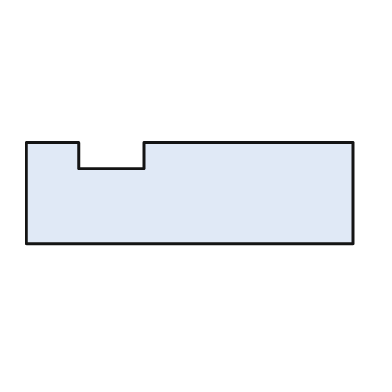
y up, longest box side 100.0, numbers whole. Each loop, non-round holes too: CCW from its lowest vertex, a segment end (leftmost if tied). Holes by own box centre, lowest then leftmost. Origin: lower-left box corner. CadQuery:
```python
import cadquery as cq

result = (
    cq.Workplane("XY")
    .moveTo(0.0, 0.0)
    .lineTo(100.0, 0.0)
    .lineTo(100.0, 31.0)
    .lineTo(36.0, 31.0)
    .lineTo(36.0, 23.0)
    .lineTo(16.0, 23.0)
    .lineTo(16.0, 31.0)
    .lineTo(0.0, 31.0)
    .close()
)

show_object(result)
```